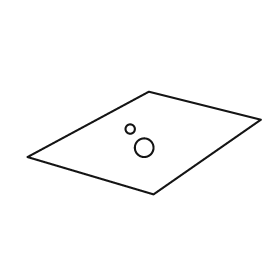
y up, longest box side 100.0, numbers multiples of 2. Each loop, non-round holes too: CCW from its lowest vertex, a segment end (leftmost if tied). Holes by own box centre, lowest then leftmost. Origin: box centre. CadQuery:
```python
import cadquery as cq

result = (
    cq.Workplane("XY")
    .moveTo(4.0, -22.0)
    .lineTo(50.0, 10.0)
    .lineTo(2.0, 22.0)
    .lineTo(-50.0, -6.0)
    .close()
    .moveTo(0.0, -2.0)
    .circle(4.0)
    .moveTo(-6.0, 6.0)
    .circle(2.0)
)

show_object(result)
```